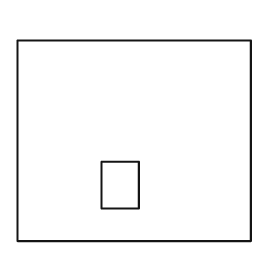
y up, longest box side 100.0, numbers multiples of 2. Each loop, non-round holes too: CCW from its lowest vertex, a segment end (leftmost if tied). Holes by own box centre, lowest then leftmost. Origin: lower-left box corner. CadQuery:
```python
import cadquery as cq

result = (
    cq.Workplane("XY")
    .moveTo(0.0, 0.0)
    .lineTo(100.0, 0.0)
    .lineTo(100.0, 86.0)
    .lineTo(0.0, 86.0)
    .close()
    .moveTo(36.0, 14.0)
    .lineTo(52.0, 14.0)
    .lineTo(52.0, 34.0)
    .lineTo(36.0, 34.0)
    .close()
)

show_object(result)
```